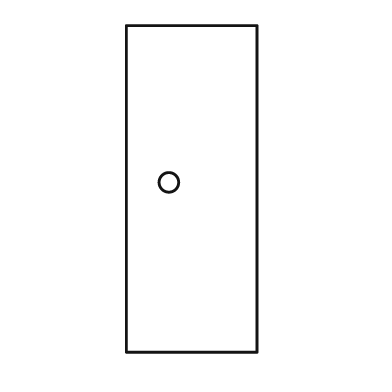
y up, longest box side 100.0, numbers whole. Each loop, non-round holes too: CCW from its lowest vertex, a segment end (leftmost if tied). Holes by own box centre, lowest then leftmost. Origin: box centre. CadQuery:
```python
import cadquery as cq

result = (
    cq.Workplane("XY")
    .moveTo(-20.0, -50.0)
    .lineTo(20.0, -50.0)
    .lineTo(20.0, 50.0)
    .lineTo(-20.0, 50.0)
    .close()
    .moveTo(-7.0, 2.0)
    .circle(3.0)
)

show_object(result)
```